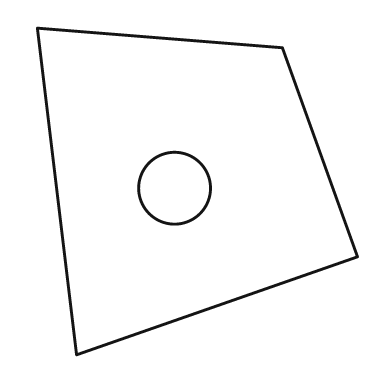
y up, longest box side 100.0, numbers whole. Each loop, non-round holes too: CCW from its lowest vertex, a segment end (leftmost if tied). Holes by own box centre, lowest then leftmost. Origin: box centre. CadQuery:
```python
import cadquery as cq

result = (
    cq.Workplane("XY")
    .moveTo(-37.0, -50.0)
    .lineTo(49.0, -20.0)
    .lineTo(26.0, 44.0)
    .lineTo(-49.0, 50.0)
    .close()
    .moveTo(-7.0, 1.0)
    .circle(11.0)
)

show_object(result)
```